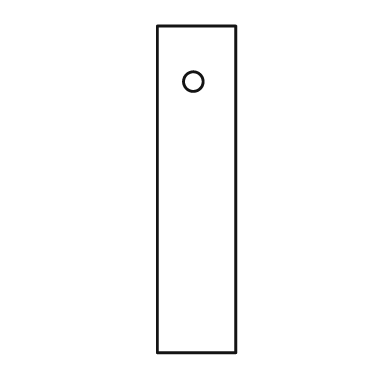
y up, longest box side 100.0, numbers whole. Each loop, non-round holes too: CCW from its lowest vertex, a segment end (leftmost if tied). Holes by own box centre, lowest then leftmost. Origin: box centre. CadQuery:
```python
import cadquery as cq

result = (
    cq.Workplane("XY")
    .moveTo(-12.0, -50.0)
    .lineTo(12.0, -50.0)
    .lineTo(12.0, 50.0)
    .lineTo(-12.0, 50.0)
    .close()
    .moveTo(-1.0, 33.0)
    .circle(3.0)
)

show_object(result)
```